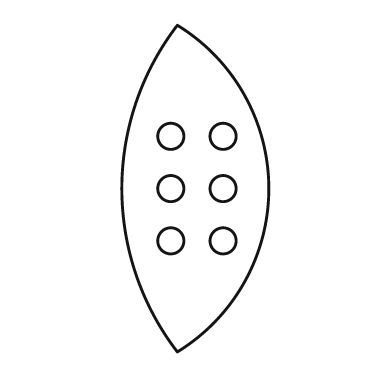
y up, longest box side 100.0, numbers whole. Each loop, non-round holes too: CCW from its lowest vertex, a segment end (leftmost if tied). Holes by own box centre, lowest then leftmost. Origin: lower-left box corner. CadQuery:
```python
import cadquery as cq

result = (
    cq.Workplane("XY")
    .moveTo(17.0, 0.0)
    .threePointArc((45.0, 50.0), (17.0, 100.0))
    .threePointArc((0.0, 50.0), (17.0, 0.0))
    .close()
    .moveTo(15.0, 34.0)
    .circle(4.0)
    .moveTo(31.0, 34.0)
    .circle(4.0)
    .moveTo(15.0, 50.0)
    .circle(4.0)
    .moveTo(31.0, 50.0)
    .circle(4.0)
    .moveTo(15.0, 66.0)
    .circle(4.0)
    .moveTo(31.0, 66.0)
    .circle(4.0)
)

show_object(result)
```